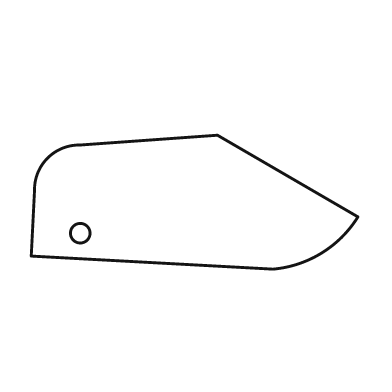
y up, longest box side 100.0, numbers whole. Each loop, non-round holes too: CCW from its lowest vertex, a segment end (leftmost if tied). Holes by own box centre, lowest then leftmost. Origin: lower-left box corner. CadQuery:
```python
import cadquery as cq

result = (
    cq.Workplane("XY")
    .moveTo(74.0, 0.0)
    .threePointArc((89.0, 5.0), (100.0, 16.0))
    .lineTo(57.0, 41.0)
    .lineTo(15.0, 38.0)
    .threePointArc((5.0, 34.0), (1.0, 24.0))
    .lineTo(0.0, 4.0)
    .close()
    .moveTo(15.0, 11.0)
    .circle(3.0)
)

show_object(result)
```